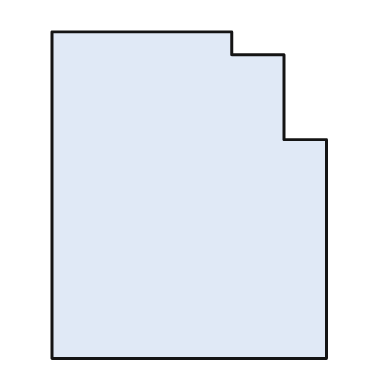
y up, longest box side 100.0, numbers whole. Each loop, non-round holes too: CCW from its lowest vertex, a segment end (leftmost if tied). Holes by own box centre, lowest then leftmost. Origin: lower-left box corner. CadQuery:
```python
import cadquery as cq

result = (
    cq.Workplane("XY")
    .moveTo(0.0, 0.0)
    .lineTo(84.0, 0.0)
    .lineTo(84.0, 67.0)
    .lineTo(71.0, 67.0)
    .lineTo(71.0, 93.0)
    .lineTo(55.0, 93.0)
    .lineTo(55.0, 100.0)
    .lineTo(0.0, 100.0)
    .close()
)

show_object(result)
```